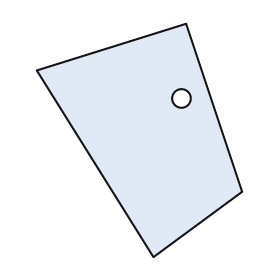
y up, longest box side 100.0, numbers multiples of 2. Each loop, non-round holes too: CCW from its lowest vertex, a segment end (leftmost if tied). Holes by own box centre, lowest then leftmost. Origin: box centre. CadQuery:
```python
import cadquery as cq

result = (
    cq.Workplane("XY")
    .moveTo(6.0, -50.0)
    .lineTo(44.0, -22.0)
    .lineTo(20.0, 50.0)
    .lineTo(-44.0, 30.0)
    .close()
    .moveTo(18.0, 18.0)
    .circle(4.0)
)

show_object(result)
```